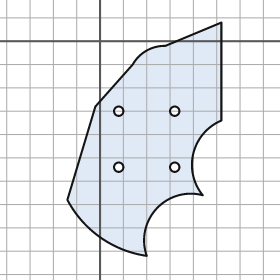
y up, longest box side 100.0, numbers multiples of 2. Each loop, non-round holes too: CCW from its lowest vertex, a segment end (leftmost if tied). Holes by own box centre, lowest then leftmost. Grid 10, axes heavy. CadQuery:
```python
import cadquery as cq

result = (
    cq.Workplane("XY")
    .moveTo(20.0, -92.0)
    .threePointArc((24.0, -72.0), (44.0, -66.0))
    .threePointArc((40.0, -48.0), (52.0, -34.0))
    .lineTo(52.0, 8.0)
    .lineTo(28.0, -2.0)
    .threePointArc((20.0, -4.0), (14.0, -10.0))
    .lineTo(-2.0, -28.0)
    .lineTo(-14.0, -68.0)
    .threePointArc((0.0, -84.0), (20.0, -92.0))
    .close()
    .moveTo(8.0, -54.0)
    .circle(2.0)
    .moveTo(32.0, -54.0)
    .circle(2.0)
    .moveTo(8.0, -30.0)
    .circle(2.0)
    .moveTo(32.0, -30.0)
    .circle(2.0)
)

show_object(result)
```